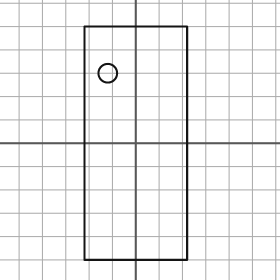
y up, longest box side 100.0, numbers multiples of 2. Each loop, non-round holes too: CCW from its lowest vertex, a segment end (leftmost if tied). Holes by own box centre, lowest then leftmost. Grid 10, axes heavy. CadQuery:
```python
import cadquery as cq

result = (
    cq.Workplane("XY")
    .moveTo(-22.0, -50.0)
    .lineTo(22.0, -50.0)
    .lineTo(22.0, 50.0)
    .lineTo(-22.0, 50.0)
    .close()
    .moveTo(-12.0, 30.0)
    .circle(4.0)
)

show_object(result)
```